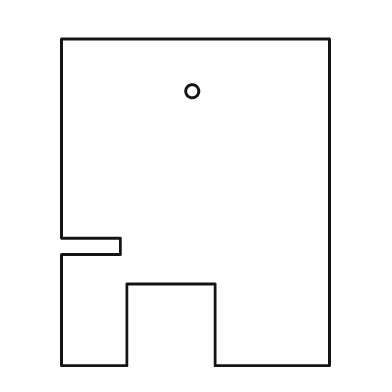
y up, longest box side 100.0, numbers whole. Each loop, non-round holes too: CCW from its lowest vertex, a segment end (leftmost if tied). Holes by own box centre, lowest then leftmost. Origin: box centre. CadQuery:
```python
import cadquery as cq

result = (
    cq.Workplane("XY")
    .moveTo(-41.0, -50.0)
    .lineTo(-21.0, -50.0)
    .lineTo(-21.0, -25.0)
    .lineTo(6.0, -25.0)
    .lineTo(6.0, -50.0)
    .lineTo(41.0, -50.0)
    .lineTo(41.0, 50.0)
    .lineTo(-41.0, 50.0)
    .lineTo(-41.0, -11.0)
    .lineTo(-23.0, -11.0)
    .lineTo(-23.0, -16.0)
    .lineTo(-41.0, -16.0)
    .close()
    .moveTo(-1.0, 34.0)
    .circle(2.0)
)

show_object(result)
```